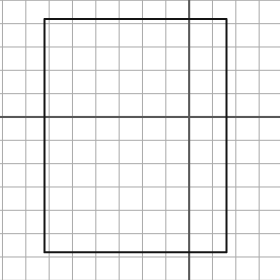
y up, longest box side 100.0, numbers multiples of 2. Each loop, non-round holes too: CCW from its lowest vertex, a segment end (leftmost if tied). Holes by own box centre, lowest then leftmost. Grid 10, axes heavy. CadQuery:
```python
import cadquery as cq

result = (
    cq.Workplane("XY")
    .moveTo(-62.0, -58.0)
    .lineTo(16.0, -58.0)
    .lineTo(16.0, 42.0)
    .lineTo(-62.0, 42.0)
    .close()
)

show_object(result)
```